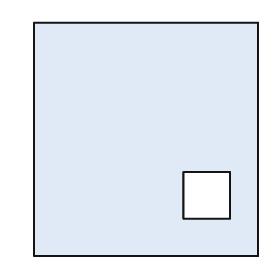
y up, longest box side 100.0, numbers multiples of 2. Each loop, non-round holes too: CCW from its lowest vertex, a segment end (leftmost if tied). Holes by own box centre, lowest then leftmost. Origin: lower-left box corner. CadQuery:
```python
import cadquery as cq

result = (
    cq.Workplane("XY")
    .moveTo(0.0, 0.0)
    .lineTo(96.0, 0.0)
    .lineTo(96.0, 100.0)
    .lineTo(0.0, 100.0)
    .close()
    .moveTo(64.0, 16.0)
    .lineTo(84.0, 16.0)
    .lineTo(84.0, 36.0)
    .lineTo(64.0, 36.0)
    .close()
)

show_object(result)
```